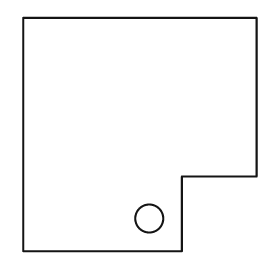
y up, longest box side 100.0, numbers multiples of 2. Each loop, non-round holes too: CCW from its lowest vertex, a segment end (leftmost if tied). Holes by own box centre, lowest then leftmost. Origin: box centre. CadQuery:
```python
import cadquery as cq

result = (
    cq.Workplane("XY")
    .moveTo(-50.0, -50.0)
    .lineTo(18.0, -50.0)
    .lineTo(18.0, -18.0)
    .lineTo(50.0, -18.0)
    .lineTo(50.0, 50.0)
    .lineTo(-50.0, 50.0)
    .close()
    .moveTo(4.0, -36.0)
    .circle(6.0)
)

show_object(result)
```